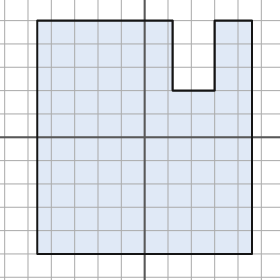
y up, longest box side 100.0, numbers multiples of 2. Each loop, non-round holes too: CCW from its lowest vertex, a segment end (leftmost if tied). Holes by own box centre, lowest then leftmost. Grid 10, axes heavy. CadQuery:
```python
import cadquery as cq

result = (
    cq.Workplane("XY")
    .moveTo(-46.0, -50.0)
    .lineTo(46.0, -50.0)
    .lineTo(46.0, 50.0)
    .lineTo(30.0, 50.0)
    .lineTo(30.0, 20.0)
    .lineTo(12.0, 20.0)
    .lineTo(12.0, 50.0)
    .lineTo(-46.0, 50.0)
    .close()
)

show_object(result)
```